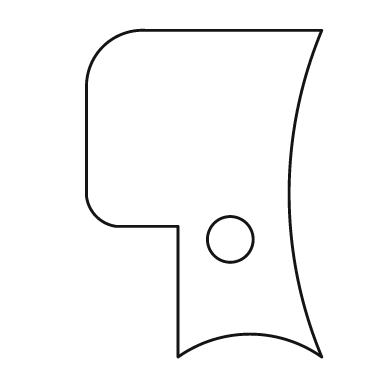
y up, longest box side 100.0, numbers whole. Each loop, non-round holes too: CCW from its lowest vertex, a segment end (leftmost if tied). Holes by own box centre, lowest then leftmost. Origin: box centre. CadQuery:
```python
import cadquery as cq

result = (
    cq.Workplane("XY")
    .moveTo(-8.0, -50.0)
    .threePointArc((14.0, -43.0), (36.0, -50.0))
    .threePointArc((26.0, 0.0), (36.0, 50.0))
    .lineTo(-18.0, 50.0)
    .threePointArc((-31.0, 45.0), (-36.0, 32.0))
    .lineTo(-36.0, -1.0)
    .threePointArc((-33.0, -7.0), (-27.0, -10.0))
    .lineTo(-8.0, -10.0)
    .close()
    .moveTo(8.0, -14.0)
    .circle(7.0)
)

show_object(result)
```